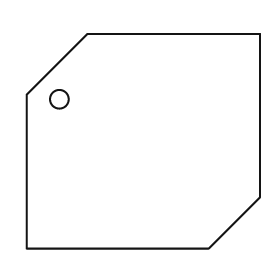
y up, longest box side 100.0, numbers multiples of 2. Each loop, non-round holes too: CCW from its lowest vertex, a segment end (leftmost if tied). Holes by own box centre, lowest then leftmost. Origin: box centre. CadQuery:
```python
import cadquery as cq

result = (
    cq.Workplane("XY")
    .moveTo(-50.0, -46.0)
    .lineTo(28.0, -46.0)
    .lineTo(50.0, -24.0)
    .lineTo(50.0, 46.0)
    .lineTo(-24.0, 46.0)
    .lineTo(-50.0, 20.0)
    .close()
    .moveTo(-36.0, 18.0)
    .circle(4.0)
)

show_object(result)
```